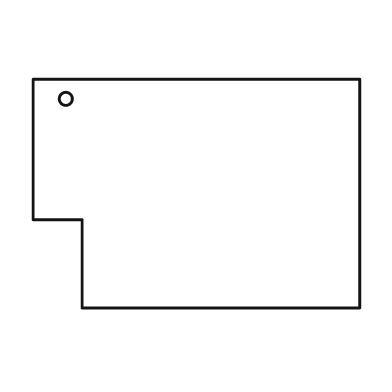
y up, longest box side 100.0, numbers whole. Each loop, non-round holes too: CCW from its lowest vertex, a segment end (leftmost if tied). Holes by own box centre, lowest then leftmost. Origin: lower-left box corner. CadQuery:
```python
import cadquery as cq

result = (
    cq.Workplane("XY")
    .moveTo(15.0, 0.0)
    .lineTo(100.0, 0.0)
    .lineTo(100.0, 70.0)
    .lineTo(0.0, 70.0)
    .lineTo(0.0, 27.0)
    .lineTo(15.0, 27.0)
    .close()
    .moveTo(10.0, 64.0)
    .circle(2.0)
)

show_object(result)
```